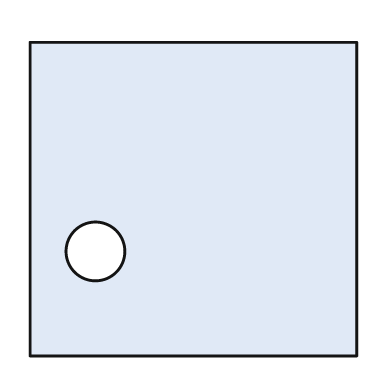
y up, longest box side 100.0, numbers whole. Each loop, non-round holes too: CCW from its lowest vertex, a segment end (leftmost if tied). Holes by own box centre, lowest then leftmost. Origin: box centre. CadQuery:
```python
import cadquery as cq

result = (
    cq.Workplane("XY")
    .moveTo(-50.0, -48.0)
    .lineTo(50.0, -48.0)
    .lineTo(50.0, 48.0)
    .lineTo(-50.0, 48.0)
    .close()
    .moveTo(-30.0, -16.0)
    .circle(9.0)
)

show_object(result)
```